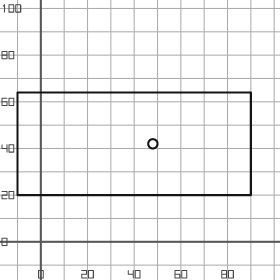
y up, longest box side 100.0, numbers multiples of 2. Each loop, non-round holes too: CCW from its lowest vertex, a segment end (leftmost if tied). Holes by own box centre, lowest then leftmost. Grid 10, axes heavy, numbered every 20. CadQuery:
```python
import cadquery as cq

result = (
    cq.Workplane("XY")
    .moveTo(-10.0, 20.0)
    .lineTo(90.0, 20.0)
    .lineTo(90.0, 64.0)
    .lineTo(-10.0, 64.0)
    .close()
    .moveTo(48.0, 42.0)
    .circle(2.0)
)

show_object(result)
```